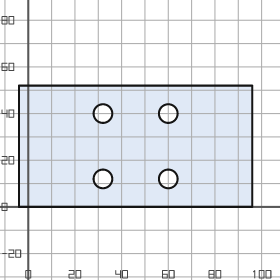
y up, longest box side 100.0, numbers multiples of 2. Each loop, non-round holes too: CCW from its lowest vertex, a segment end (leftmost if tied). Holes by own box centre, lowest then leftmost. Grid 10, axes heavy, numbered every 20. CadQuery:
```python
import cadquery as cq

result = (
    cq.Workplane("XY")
    .moveTo(-4.0, 0.0)
    .lineTo(96.0, 0.0)
    .lineTo(96.0, 52.0)
    .lineTo(-4.0, 52.0)
    .close()
    .moveTo(32.0, 12.0)
    .circle(4.0)
    .moveTo(60.0, 12.0)
    .circle(4.0)
    .moveTo(32.0, 40.0)
    .circle(4.0)
    .moveTo(60.0, 40.0)
    .circle(4.0)
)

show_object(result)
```